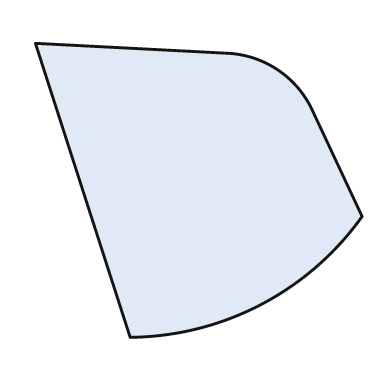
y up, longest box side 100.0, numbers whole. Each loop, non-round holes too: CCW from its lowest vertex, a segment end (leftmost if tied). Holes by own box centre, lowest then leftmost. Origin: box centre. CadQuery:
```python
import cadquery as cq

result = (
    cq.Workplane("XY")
    .moveTo(-21.0, -45.0)
    .threePointArc((19.0, -35.0), (50.0, -8.0))
    .lineTo(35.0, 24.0)
    .threePointArc((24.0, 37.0), (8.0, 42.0))
    .lineTo(-50.0, 45.0)
    .close()
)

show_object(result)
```